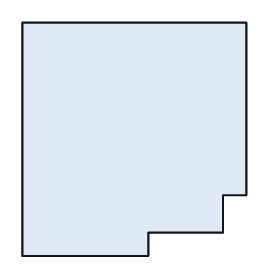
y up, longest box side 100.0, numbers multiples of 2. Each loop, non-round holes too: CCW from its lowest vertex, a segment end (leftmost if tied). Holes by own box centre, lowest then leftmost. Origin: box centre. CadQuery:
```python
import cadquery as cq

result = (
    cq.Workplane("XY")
    .moveTo(-48.0, -50.0)
    .lineTo(6.0, -50.0)
    .lineTo(6.0, -40.0)
    .lineTo(38.0, -40.0)
    .lineTo(38.0, -24.0)
    .lineTo(48.0, -24.0)
    .lineTo(48.0, 50.0)
    .lineTo(-48.0, 50.0)
    .close()
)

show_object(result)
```